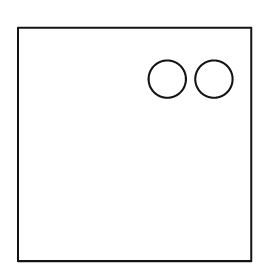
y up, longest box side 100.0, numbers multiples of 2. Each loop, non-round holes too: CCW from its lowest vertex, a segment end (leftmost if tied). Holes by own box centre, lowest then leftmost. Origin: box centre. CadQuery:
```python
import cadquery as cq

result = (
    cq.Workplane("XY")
    .moveTo(-50.0, -50.0)
    .lineTo(50.0, -50.0)
    .lineTo(50.0, 50.0)
    .lineTo(-50.0, 50.0)
    .close()
    .moveTo(14.0, 28.0)
    .circle(8.0)
    .moveTo(34.0, 28.0)
    .circle(8.0)
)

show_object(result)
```